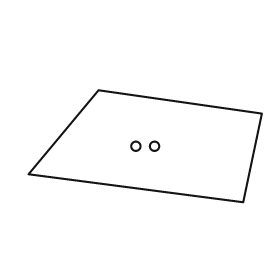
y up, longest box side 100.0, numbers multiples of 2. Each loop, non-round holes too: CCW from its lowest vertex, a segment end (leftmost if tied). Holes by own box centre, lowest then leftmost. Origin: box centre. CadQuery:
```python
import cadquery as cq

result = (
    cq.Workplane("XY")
    .moveTo(42.0, -24.0)
    .lineTo(50.0, 14.0)
    .lineTo(-20.0, 24.0)
    .lineTo(-50.0, -12.0)
    .close()
    .moveTo(-4.0, 0.0)
    .circle(2.0)
    .moveTo(4.0, 0.0)
    .circle(2.0)
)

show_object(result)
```